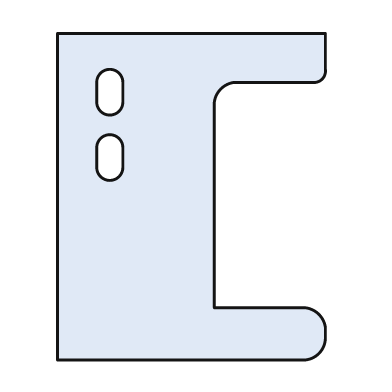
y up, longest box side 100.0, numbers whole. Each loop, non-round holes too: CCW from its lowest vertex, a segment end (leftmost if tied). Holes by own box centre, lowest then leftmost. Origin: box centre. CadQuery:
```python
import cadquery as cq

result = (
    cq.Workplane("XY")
    .moveTo(-41.0, -50.0)
    .lineTo(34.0, -50.0)
    .threePointArc((39.0, -48.0), (41.0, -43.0))
    .lineTo(41.0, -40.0)
    .threePointArc((39.0, -36.0), (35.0, -34.0))
    .lineTo(7.0, -34.0)
    .lineTo(7.0, 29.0)
    .threePointArc((9.0, 33.0), (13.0, 35.0))
    .lineTo(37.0, 35.0)
    .threePointArc((40.0, 36.0), (41.0, 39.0))
    .lineTo(41.0, 50.0)
    .lineTo(-41.0, 50.0)
    .close()
    .moveTo(-29.0, 9.0)
    .threePointArc((-25.0, 5.0), (-21.0, 9.0))
    .lineTo(-21.0, 15.0)
    .threePointArc((-25.0, 19.0), (-29.0, 15.0))
    .close()
    .moveTo(-29.0, 29.0)
    .threePointArc((-25.0, 25.0), (-21.0, 29.0))
    .lineTo(-21.0, 35.0)
    .threePointArc((-25.0, 39.0), (-29.0, 35.0))
    .close()
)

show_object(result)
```